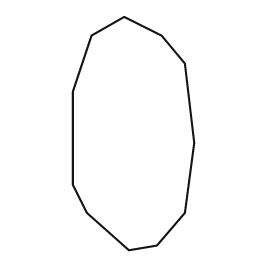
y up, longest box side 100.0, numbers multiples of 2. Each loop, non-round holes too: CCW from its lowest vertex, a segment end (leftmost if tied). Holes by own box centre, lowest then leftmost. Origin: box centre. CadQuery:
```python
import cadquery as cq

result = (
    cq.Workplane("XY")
    .moveTo(-2.0, -50.0)
    .lineTo(10.0, -48.0)
    .lineTo(22.0, -34.0)
    .lineTo(26.0, -4.0)
    .lineTo(22.0, 30.0)
    .lineTo(12.0, 42.0)
    .lineTo(-4.0, 50.0)
    .lineTo(-18.0, 42.0)
    .lineTo(-26.0, 18.0)
    .lineTo(-26.0, -22.0)
    .lineTo(-20.0, -34.0)
    .close()
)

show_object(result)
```